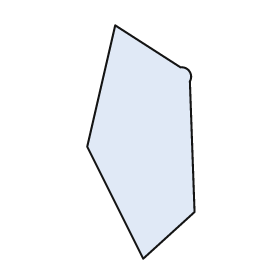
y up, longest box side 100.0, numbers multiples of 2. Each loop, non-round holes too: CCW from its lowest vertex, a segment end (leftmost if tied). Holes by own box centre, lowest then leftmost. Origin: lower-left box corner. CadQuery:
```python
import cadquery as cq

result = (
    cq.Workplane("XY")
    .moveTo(24.0, 0.0)
    .lineTo(46.0, 20.0)
    .lineTo(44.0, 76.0)
    .threePointArc((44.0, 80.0), (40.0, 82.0))
    .lineTo(12.0, 100.0)
    .lineTo(0.0, 48.0)
    .close()
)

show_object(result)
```